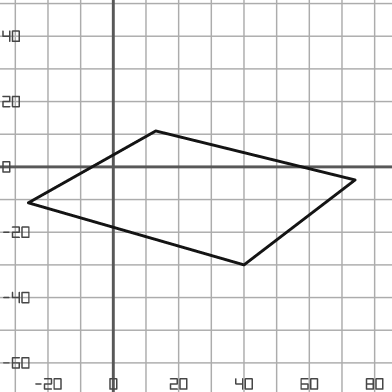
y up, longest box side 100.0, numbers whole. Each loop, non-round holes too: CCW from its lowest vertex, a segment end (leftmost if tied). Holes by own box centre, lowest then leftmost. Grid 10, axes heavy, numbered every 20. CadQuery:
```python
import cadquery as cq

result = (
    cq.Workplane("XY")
    .moveTo(40.0, -30.0)
    .lineTo(74.0, -4.0)
    .lineTo(13.0, 11.0)
    .lineTo(-26.0, -11.0)
    .close()
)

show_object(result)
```